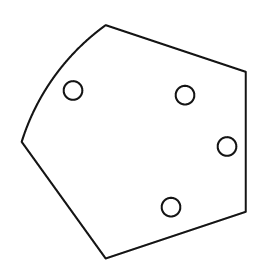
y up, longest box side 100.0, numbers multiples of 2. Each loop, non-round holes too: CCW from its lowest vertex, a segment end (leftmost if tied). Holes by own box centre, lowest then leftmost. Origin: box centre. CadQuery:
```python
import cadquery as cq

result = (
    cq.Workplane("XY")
    .moveTo(-12.0, -50.0)
    .lineTo(48.0, -30.0)
    .lineTo(48.0, 30.0)
    .lineTo(-12.0, 50.0)
    .threePointArc((-34.0, 28.0), (-48.0, 0.0))
    .close()
    .moveTo(16.0, -28.0)
    .circle(4.0)
    .moveTo(40.0, -2.0)
    .circle(4.0)
    .moveTo(22.0, 20.0)
    .circle(4.0)
    .moveTo(-26.0, 22.0)
    .circle(4.0)
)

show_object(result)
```